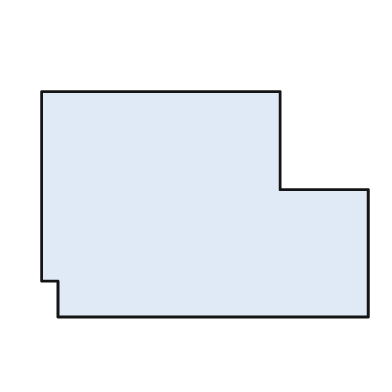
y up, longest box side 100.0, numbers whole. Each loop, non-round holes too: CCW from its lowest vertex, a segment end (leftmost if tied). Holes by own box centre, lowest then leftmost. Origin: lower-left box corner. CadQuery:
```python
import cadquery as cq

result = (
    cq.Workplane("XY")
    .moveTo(5.0, 0.0)
    .lineTo(100.0, 0.0)
    .lineTo(100.0, 39.0)
    .lineTo(73.0, 39.0)
    .lineTo(73.0, 69.0)
    .lineTo(0.0, 69.0)
    .lineTo(0.0, 11.0)
    .lineTo(5.0, 11.0)
    .close()
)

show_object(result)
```